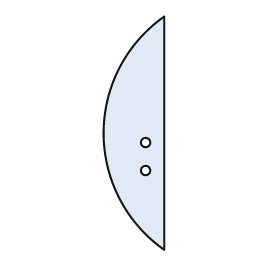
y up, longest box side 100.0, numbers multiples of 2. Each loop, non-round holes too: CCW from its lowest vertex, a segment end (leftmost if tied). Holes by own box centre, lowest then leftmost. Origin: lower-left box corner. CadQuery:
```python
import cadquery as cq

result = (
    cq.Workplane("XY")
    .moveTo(26.0, 0.0)
    .lineTo(26.0, 100.0)
    .threePointArc((0.0, 50.0), (26.0, 0.0))
    .close()
    .moveTo(18.0, 34.0)
    .circle(2.0)
    .moveTo(18.0, 46.0)
    .circle(2.0)
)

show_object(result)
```